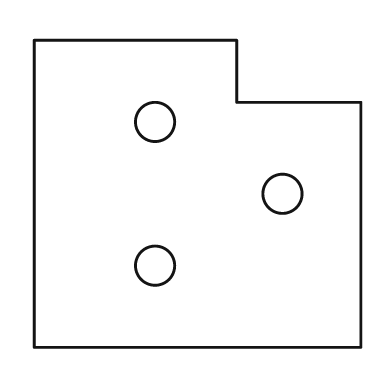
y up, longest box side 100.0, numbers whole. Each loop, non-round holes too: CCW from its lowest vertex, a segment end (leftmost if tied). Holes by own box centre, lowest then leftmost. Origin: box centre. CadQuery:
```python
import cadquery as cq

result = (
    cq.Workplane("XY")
    .moveTo(-50.0, -47.0)
    .lineTo(50.0, -47.0)
    .lineTo(50.0, 28.0)
    .lineTo(12.0, 28.0)
    .lineTo(12.0, 47.0)
    .lineTo(-50.0, 47.0)
    .close()
    .moveTo(-13.0, -22.0)
    .circle(6.0)
    .moveTo(26.0, 0.0)
    .circle(6.0)
    .moveTo(-13.0, 22.0)
    .circle(6.0)
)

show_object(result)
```